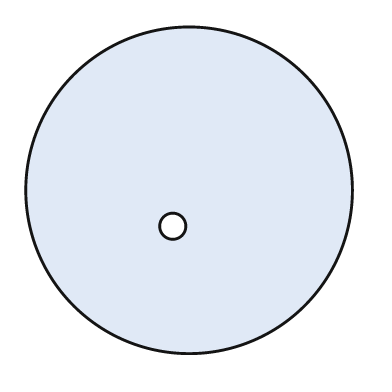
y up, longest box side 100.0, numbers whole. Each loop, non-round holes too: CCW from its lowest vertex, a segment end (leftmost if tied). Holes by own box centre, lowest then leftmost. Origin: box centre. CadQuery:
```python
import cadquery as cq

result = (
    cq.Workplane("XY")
    .moveTo(0.0, 0.0)
    .circle(50.0)
    .moveTo(-5.0, -11.0)
    .circle(4.0)
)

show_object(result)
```